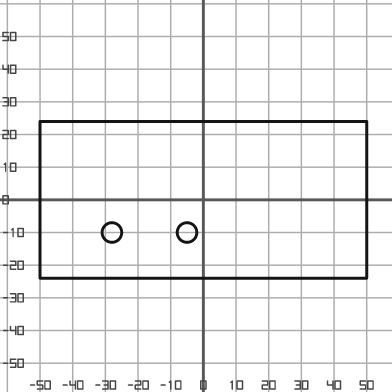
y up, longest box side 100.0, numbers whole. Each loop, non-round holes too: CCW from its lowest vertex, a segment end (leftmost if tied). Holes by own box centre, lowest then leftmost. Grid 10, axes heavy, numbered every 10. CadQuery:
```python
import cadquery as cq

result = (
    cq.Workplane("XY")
    .moveTo(-50.0, -24.0)
    .lineTo(50.0, -24.0)
    .lineTo(50.0, 24.0)
    .lineTo(-50.0, 24.0)
    .close()
    .moveTo(-28.0, -10.0)
    .circle(3.0)
    .moveTo(-5.0, -10.0)
    .circle(3.0)
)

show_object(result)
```